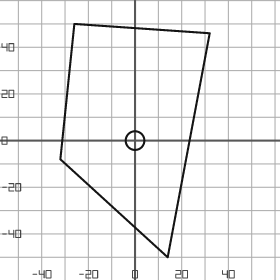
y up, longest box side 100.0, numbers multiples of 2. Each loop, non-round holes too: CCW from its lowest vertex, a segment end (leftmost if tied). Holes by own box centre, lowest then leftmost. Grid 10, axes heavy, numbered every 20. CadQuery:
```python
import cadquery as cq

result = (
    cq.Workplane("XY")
    .moveTo(14.0, -50.0)
    .lineTo(32.0, 46.0)
    .lineTo(-26.0, 50.0)
    .lineTo(-32.0, -8.0)
    .close()
    .moveTo(0.0, 0.0)
    .circle(4.0)
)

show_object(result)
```